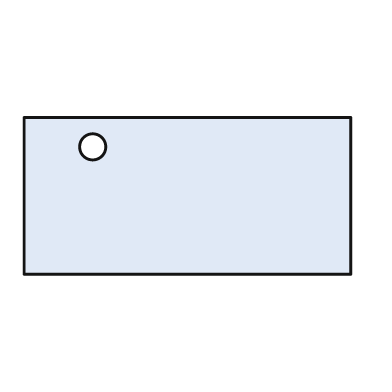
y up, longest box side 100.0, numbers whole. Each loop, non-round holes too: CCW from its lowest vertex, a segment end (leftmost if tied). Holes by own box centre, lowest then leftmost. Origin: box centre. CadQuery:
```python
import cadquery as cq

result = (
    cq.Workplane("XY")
    .moveTo(-50.0, -24.0)
    .lineTo(50.0, -24.0)
    .lineTo(50.0, 24.0)
    .lineTo(-50.0, 24.0)
    .close()
    .moveTo(-29.0, 15.0)
    .circle(4.0)
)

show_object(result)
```